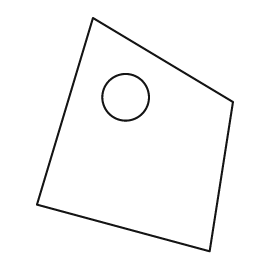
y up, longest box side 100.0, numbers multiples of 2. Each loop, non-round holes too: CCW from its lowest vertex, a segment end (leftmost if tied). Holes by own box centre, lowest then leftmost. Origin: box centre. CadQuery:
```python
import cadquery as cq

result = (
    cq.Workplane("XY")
    .moveTo(32.0, -50.0)
    .lineTo(42.0, 14.0)
    .lineTo(-18.0, 50.0)
    .lineTo(-42.0, -30.0)
    .close()
    .moveTo(-4.0, 16.0)
    .circle(10.0)
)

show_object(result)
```